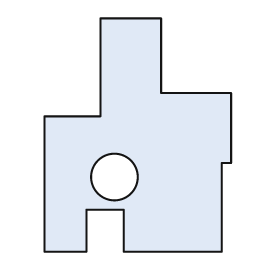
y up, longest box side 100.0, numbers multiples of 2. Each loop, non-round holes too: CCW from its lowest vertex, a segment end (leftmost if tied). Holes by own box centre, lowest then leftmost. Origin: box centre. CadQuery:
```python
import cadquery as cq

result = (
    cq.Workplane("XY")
    .moveTo(-40.0, -50.0)
    .lineTo(-22.0, -50.0)
    .lineTo(-22.0, -32.0)
    .lineTo(-6.0, -32.0)
    .lineTo(-6.0, -50.0)
    .lineTo(36.0, -50.0)
    .lineTo(36.0, -12.0)
    .lineTo(40.0, -12.0)
    .lineTo(40.0, 18.0)
    .lineTo(10.0, 18.0)
    .lineTo(10.0, 50.0)
    .lineTo(-16.0, 50.0)
    .lineTo(-16.0, 8.0)
    .lineTo(-40.0, 8.0)
    .close()
    .moveTo(-10.0, -18.0)
    .circle(10.0)
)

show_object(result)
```